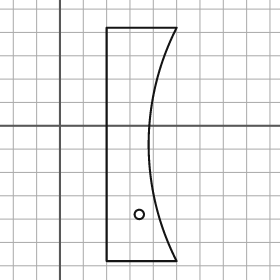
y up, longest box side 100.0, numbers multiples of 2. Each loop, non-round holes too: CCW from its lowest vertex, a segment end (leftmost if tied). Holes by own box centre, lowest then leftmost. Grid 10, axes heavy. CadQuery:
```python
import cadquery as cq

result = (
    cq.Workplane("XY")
    .moveTo(20.0, -58.0)
    .lineTo(50.0, -58.0)
    .threePointArc((38.0, -8.0), (50.0, 42.0))
    .lineTo(20.0, 42.0)
    .close()
    .moveTo(34.0, -38.0)
    .circle(2.0)
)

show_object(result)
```